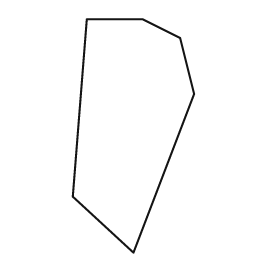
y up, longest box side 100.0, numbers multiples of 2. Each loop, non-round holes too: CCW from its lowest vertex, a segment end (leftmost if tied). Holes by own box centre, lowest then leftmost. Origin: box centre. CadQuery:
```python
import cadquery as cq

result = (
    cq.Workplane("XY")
    .moveTo(0.0, -50.0)
    .lineTo(26.0, 18.0)
    .lineTo(20.0, 42.0)
    .lineTo(4.0, 50.0)
    .lineTo(-20.0, 50.0)
    .lineTo(-26.0, -26.0)
    .close()
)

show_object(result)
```